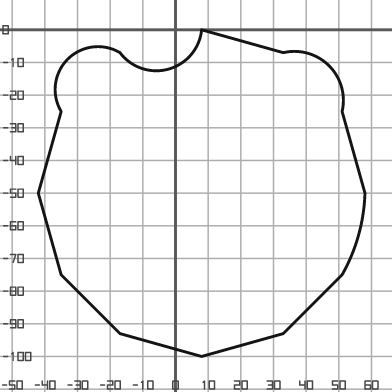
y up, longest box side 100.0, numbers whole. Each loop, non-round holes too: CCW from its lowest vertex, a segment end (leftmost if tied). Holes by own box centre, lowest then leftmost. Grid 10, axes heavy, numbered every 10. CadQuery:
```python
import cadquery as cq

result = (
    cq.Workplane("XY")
    .moveTo(8.0, -100.0)
    .lineTo(33.0, -93.0)
    .lineTo(51.0, -75.0)
    .threePointArc((56.0, -63.0), (58.0, -50.0))
    .lineTo(51.0, -25.0)
    .threePointArc((47.0, -11.0), (33.0, -7.0))
    .lineTo(8.0, 0.0)
    .threePointArc((-2.0, -12.0), (-17.0, -7.0))
    .threePointArc((-33.0, -9.0), (-35.0, -25.0))
    .lineTo(-42.0, -50.0)
    .lineTo(-35.0, -75.0)
    .lineTo(-17.0, -93.0)
    .close()
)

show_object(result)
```